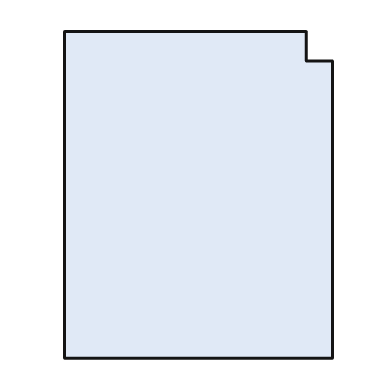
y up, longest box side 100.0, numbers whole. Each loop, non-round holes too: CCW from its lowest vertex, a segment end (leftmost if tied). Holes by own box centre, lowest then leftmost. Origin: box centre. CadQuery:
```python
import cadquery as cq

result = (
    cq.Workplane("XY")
    .moveTo(-41.0, -50.0)
    .lineTo(41.0, -50.0)
    .lineTo(41.0, 41.0)
    .lineTo(33.0, 41.0)
    .lineTo(33.0, 50.0)
    .lineTo(-41.0, 50.0)
    .close()
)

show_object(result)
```